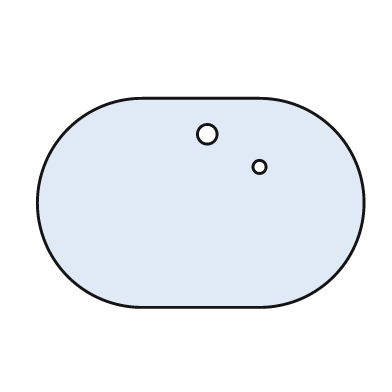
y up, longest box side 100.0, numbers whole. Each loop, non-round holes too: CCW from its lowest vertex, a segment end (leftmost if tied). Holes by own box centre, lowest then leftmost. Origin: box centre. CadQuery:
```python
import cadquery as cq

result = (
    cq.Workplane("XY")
    .moveTo(-18.0, -32.0)
    .lineTo(18.0, -32.0)
    .threePointArc((50.0, 0.0), (18.0, 32.0))
    .lineTo(-18.0, 32.0)
    .threePointArc((-50.0, 0.0), (-18.0, -32.0))
    .close()
    .moveTo(18.0, 11.0)
    .circle(2.0)
    .moveTo(2.0, 21.0)
    .circle(3.0)
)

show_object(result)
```